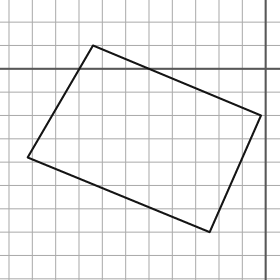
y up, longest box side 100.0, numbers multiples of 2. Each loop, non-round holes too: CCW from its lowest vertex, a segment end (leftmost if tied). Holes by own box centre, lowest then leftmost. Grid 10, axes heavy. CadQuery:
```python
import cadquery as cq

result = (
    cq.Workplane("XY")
    .moveTo(-24.0, -70.0)
    .lineTo(-2.0, -20.0)
    .lineTo(-74.0, 10.0)
    .lineTo(-102.0, -38.0)
    .close()
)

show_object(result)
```